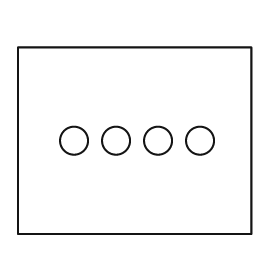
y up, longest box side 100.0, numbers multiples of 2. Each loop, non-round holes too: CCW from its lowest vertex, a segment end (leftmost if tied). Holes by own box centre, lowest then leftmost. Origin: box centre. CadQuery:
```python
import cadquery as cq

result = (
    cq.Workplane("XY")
    .moveTo(-50.0, -40.0)
    .lineTo(50.0, -40.0)
    .lineTo(50.0, 40.0)
    .lineTo(-50.0, 40.0)
    .close()
    .moveTo(-26.0, 0.0)
    .circle(6.0)
    .moveTo(-8.0, 0.0)
    .circle(6.0)
    .moveTo(10.0, 0.0)
    .circle(6.0)
    .moveTo(28.0, 0.0)
    .circle(6.0)
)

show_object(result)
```